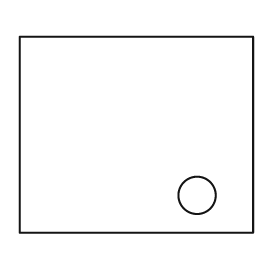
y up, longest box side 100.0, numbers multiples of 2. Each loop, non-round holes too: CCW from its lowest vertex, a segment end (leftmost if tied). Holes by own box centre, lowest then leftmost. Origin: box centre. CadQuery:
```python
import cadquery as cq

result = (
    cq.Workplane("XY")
    .moveTo(-50.0, -42.0)
    .lineTo(50.0, -42.0)
    .lineTo(50.0, 42.0)
    .lineTo(-50.0, 42.0)
    .close()
    .moveTo(26.0, -26.0)
    .circle(8.0)
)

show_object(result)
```